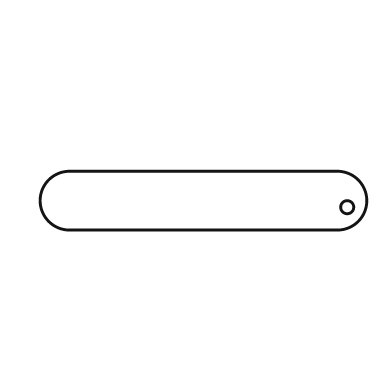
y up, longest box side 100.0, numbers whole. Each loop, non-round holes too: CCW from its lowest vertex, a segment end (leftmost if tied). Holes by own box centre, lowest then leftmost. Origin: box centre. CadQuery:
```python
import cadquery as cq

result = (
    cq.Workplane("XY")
    .moveTo(-41.0, -9.0)
    .lineTo(41.0, -9.0)
    .threePointArc((50.0, 0.0), (41.0, 9.0))
    .lineTo(-41.0, 9.0)
    .threePointArc((-50.0, 0.0), (-41.0, -9.0))
    .close()
    .moveTo(44.0, -2.0)
    .circle(2.0)
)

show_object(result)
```